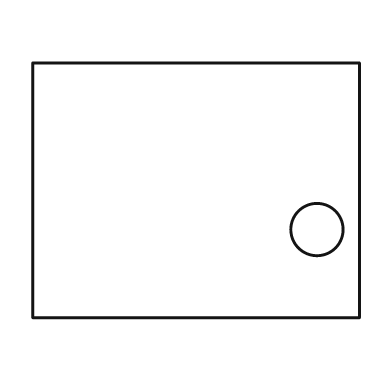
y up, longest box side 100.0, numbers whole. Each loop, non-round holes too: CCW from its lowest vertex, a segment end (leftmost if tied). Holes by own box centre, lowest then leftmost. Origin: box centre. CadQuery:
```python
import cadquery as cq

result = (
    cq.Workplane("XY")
    .moveTo(-50.0, -39.0)
    .lineTo(50.0, -39.0)
    .lineTo(50.0, 39.0)
    .lineTo(-50.0, 39.0)
    .close()
    .moveTo(37.0, -12.0)
    .circle(8.0)
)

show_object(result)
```